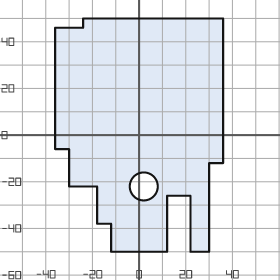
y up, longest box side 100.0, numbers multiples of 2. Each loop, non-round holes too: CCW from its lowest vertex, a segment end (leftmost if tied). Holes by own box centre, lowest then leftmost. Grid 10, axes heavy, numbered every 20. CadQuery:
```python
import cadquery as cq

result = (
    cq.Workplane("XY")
    .moveTo(-12.0, -50.0)
    .lineTo(12.0, -50.0)
    .lineTo(12.0, -26.0)
    .lineTo(22.0, -26.0)
    .lineTo(22.0, -50.0)
    .lineTo(30.0, -50.0)
    .lineTo(30.0, -12.0)
    .lineTo(36.0, -12.0)
    .lineTo(36.0, 50.0)
    .lineTo(-24.0, 50.0)
    .lineTo(-24.0, 46.0)
    .lineTo(-36.0, 46.0)
    .lineTo(-36.0, -6.0)
    .lineTo(-30.0, -6.0)
    .lineTo(-30.0, -22.0)
    .lineTo(-18.0, -22.0)
    .lineTo(-18.0, -38.0)
    .lineTo(-12.0, -38.0)
    .close()
    .moveTo(2.0, -22.0)
    .circle(6.0)
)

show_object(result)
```